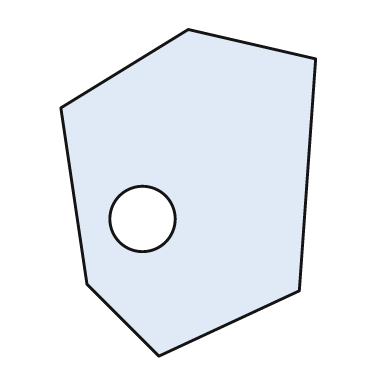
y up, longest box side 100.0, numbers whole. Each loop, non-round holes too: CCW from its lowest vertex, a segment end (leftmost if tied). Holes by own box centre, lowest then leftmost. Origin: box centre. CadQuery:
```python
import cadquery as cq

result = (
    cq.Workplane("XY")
    .moveTo(-9.0, -50.0)
    .lineTo(34.0, -30.0)
    .lineTo(39.0, 41.0)
    .lineTo(0.0, 50.0)
    .lineTo(-39.0, 26.0)
    .lineTo(-31.0, -28.0)
    .close()
    .moveTo(-14.0, -8.0)
    .circle(10.0)
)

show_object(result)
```